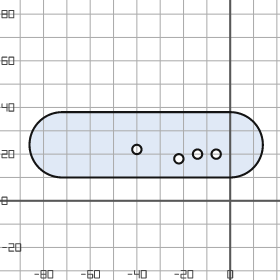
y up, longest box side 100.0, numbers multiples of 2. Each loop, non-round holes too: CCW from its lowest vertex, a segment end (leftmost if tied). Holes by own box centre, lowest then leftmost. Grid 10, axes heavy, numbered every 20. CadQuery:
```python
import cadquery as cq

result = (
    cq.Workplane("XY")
    .moveTo(-72.0, 10.0)
    .lineTo(0.0, 10.0)
    .threePointArc((14.0, 24.0), (0.0, 38.0))
    .lineTo(-72.0, 38.0)
    .threePointArc((-86.0, 24.0), (-72.0, 10.0))
    .close()
    .moveTo(-22.0, 18.0)
    .circle(2.0)
    .moveTo(-14.0, 20.0)
    .circle(2.0)
    .moveTo(-6.0, 20.0)
    .circle(2.0)
    .moveTo(-40.0, 22.0)
    .circle(2.0)
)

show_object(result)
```